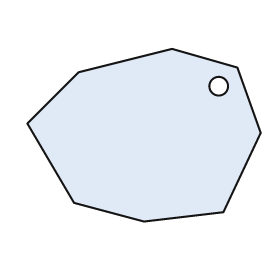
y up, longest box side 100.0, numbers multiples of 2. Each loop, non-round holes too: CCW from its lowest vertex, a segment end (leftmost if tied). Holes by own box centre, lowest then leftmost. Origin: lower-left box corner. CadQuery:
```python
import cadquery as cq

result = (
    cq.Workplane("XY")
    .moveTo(50.0, 0.0)
    .lineTo(84.0, 4.0)
    .lineTo(100.0, 38.0)
    .lineTo(90.0, 66.0)
    .lineTo(62.0, 74.0)
    .lineTo(22.0, 64.0)
    .lineTo(0.0, 42.0)
    .lineTo(20.0, 8.0)
    .close()
    .moveTo(82.0, 58.0)
    .circle(4.0)
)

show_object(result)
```